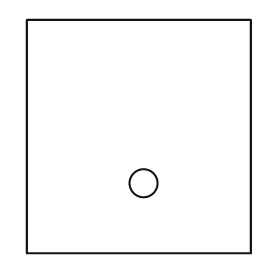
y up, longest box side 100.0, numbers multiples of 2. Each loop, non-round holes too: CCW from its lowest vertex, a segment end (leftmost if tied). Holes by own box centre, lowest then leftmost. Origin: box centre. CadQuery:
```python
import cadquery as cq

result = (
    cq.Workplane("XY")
    .moveTo(-48.0, -50.0)
    .lineTo(48.0, -50.0)
    .lineTo(48.0, 50.0)
    .lineTo(-48.0, 50.0)
    .close()
    .moveTo(2.0, -20.0)
    .circle(6.0)
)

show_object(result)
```